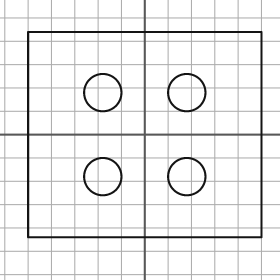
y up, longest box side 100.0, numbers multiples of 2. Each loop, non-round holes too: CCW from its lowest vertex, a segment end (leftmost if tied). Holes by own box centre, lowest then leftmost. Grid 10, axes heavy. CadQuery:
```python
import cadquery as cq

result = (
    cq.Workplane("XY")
    .moveTo(-50.0, -44.0)
    .lineTo(50.0, -44.0)
    .lineTo(50.0, 44.0)
    .lineTo(-50.0, 44.0)
    .close()
    .moveTo(-18.0, -18.0)
    .circle(8.0)
    .moveTo(18.0, -18.0)
    .circle(8.0)
    .moveTo(-18.0, 18.0)
    .circle(8.0)
    .moveTo(18.0, 18.0)
    .circle(8.0)
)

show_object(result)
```